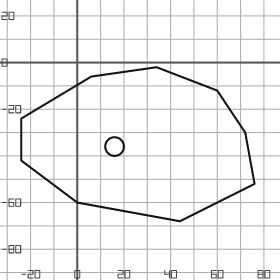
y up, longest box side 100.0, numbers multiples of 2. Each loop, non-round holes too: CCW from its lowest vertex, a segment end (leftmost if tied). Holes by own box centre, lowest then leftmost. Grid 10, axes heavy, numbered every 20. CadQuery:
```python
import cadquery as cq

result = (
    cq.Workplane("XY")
    .moveTo(44.0, -68.0)
    .lineTo(76.0, -52.0)
    .lineTo(72.0, -30.0)
    .lineTo(60.0, -12.0)
    .lineTo(34.0, -2.0)
    .lineTo(6.0, -6.0)
    .lineTo(-24.0, -24.0)
    .lineTo(-24.0, -42.0)
    .lineTo(0.0, -60.0)
    .close()
    .moveTo(16.0, -36.0)
    .circle(4.0)
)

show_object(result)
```